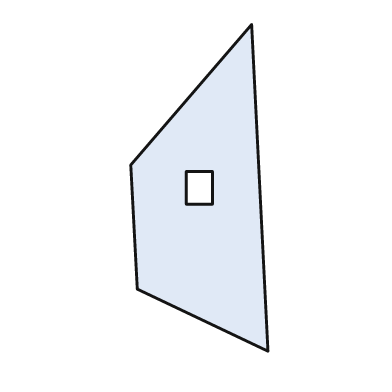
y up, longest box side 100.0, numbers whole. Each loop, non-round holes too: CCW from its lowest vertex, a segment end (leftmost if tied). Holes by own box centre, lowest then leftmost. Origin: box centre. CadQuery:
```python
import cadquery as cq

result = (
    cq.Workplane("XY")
    .moveTo(21.0, -50.0)
    .lineTo(16.0, 50.0)
    .lineTo(-21.0, 7.0)
    .lineTo(-19.0, -31.0)
    .close()
    .moveTo(-4.0, -5.0)
    .lineTo(4.0, -5.0)
    .lineTo(4.0, 5.0)
    .lineTo(-4.0, 5.0)
    .close()
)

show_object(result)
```